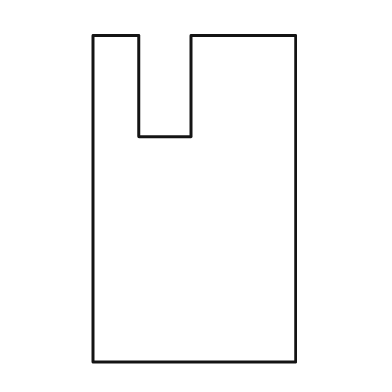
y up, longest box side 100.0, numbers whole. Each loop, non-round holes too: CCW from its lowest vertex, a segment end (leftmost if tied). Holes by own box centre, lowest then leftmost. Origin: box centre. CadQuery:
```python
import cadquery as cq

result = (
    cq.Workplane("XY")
    .moveTo(-31.0, -50.0)
    .lineTo(31.0, -50.0)
    .lineTo(31.0, 50.0)
    .lineTo(-1.0, 50.0)
    .lineTo(-1.0, 19.0)
    .lineTo(-17.0, 19.0)
    .lineTo(-17.0, 50.0)
    .lineTo(-31.0, 50.0)
    .close()
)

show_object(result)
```